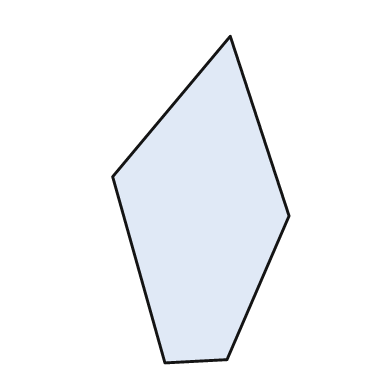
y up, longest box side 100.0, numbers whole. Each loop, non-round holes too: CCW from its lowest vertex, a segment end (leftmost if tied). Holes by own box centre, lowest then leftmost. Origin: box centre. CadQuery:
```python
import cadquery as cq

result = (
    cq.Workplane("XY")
    .moveTo(-11.0, -50.0)
    .lineTo(8.0, -49.0)
    .lineTo(27.0, -5.0)
    .lineTo(9.0, 50.0)
    .lineTo(-27.0, 7.0)
    .close()
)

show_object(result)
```